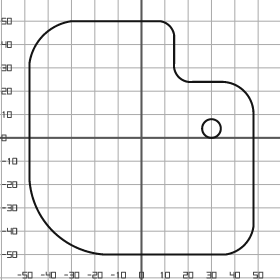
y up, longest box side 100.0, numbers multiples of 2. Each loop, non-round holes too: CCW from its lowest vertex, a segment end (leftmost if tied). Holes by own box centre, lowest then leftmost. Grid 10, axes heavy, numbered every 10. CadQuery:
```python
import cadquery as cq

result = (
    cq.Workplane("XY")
    .moveTo(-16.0, -50.0)
    .lineTo(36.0, -50.0)
    .threePointArc((44.0, -46.0), (48.0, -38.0))
    .lineTo(48.0, 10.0)
    .threePointArc((44.0, 20.0), (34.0, 24.0))
    .lineTo(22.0, 24.0)
    .threePointArc((16.0, 26.0), (14.0, 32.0))
    .lineTo(14.0, 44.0)
    .threePointArc((12.0, 48.0), (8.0, 50.0))
    .lineTo(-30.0, 50.0)
    .threePointArc((-42.0, 44.0), (-48.0, 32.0))
    .lineTo(-48.0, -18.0)
    .threePointArc((-38.0, -40.0), (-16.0, -50.0))
    .close()
    .moveTo(30.0, 4.0)
    .circle(4.0)
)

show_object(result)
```